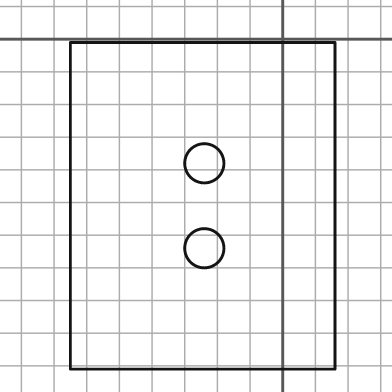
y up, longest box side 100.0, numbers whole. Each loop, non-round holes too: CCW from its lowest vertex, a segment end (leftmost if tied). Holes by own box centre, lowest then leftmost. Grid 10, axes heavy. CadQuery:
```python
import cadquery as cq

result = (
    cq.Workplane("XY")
    .moveTo(-65.0, -101.0)
    .lineTo(16.0, -101.0)
    .lineTo(16.0, -1.0)
    .lineTo(-65.0, -1.0)
    .close()
    .moveTo(-24.0, -64.0)
    .circle(6.0)
    .moveTo(-24.0, -38.0)
    .circle(6.0)
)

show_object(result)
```